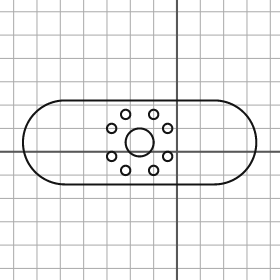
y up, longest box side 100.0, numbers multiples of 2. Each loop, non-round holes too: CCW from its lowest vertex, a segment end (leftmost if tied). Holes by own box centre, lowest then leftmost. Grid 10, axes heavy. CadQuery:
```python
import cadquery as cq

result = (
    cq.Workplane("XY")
    .moveTo(-48.0, -14.0)
    .lineTo(16.0, -14.0)
    .threePointArc((34.0, 4.0), (16.0, 22.0))
    .lineTo(-48.0, 22.0)
    .threePointArc((-66.0, 4.0), (-48.0, -14.0))
    .close()
    .moveTo(-22.0, -8.0)
    .circle(2.0)
    .moveTo(-10.0, -8.0)
    .circle(2.0)
    .moveTo(-28.0, -2.0)
    .circle(2.0)
    .moveTo(-4.0, -2.0)
    .circle(2.0)
    .moveTo(-16.0, 4.0)
    .circle(6.0)
    .moveTo(-28.0, 10.0)
    .circle(2.0)
    .moveTo(-4.0, 10.0)
    .circle(2.0)
    .moveTo(-22.0, 16.0)
    .circle(2.0)
    .moveTo(-10.0, 16.0)
    .circle(2.0)
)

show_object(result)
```